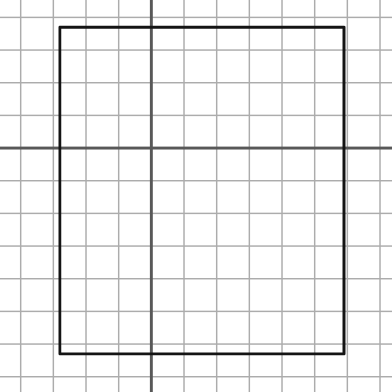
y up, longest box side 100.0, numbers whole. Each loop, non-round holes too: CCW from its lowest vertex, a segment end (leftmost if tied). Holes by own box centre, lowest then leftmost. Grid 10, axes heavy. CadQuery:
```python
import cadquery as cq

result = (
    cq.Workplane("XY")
    .moveTo(-28.0, -63.0)
    .lineTo(59.0, -63.0)
    .lineTo(59.0, 37.0)
    .lineTo(-28.0, 37.0)
    .close()
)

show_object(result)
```